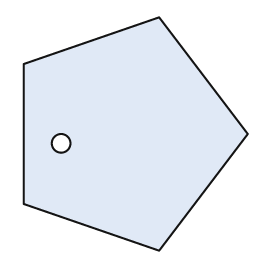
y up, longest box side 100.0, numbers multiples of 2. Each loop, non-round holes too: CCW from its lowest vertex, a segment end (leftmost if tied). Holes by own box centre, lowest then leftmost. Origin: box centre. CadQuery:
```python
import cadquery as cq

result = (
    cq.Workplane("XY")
    .moveTo(10.0, -50.0)
    .lineTo(48.0, 0.0)
    .lineTo(10.0, 50.0)
    .lineTo(-48.0, 30.0)
    .lineTo(-48.0, -30.0)
    .close()
    .moveTo(-32.0, -4.0)
    .circle(4.0)
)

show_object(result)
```